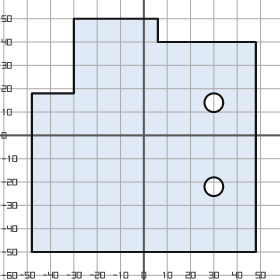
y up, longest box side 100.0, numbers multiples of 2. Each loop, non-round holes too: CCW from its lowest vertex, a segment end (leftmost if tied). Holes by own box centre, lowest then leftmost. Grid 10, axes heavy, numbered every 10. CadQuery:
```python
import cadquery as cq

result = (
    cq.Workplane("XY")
    .moveTo(-48.0, -50.0)
    .lineTo(48.0, -50.0)
    .lineTo(48.0, 40.0)
    .lineTo(6.0, 40.0)
    .lineTo(6.0, 50.0)
    .lineTo(-30.0, 50.0)
    .lineTo(-30.0, 18.0)
    .lineTo(-48.0, 18.0)
    .close()
    .moveTo(30.0, -22.0)
    .circle(4.0)
    .moveTo(30.0, 14.0)
    .circle(4.0)
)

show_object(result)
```